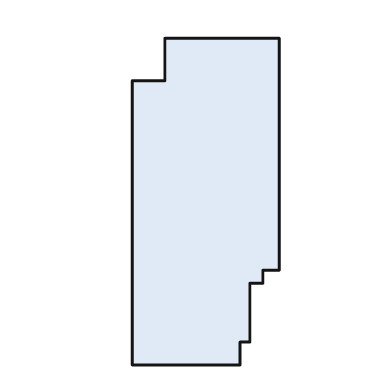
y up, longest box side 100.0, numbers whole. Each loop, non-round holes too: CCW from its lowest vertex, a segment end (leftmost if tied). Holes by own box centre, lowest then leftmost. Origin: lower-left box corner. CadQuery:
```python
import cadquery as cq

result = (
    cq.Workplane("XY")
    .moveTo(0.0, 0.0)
    .lineTo(33.0, 0.0)
    .lineTo(33.0, 7.0)
    .lineTo(36.0, 7.0)
    .lineTo(36.0, 25.0)
    .lineTo(40.0, 25.0)
    .lineTo(40.0, 29.0)
    .lineTo(45.0, 29.0)
    .lineTo(45.0, 100.0)
    .lineTo(10.0, 100.0)
    .lineTo(10.0, 87.0)
    .lineTo(0.0, 87.0)
    .close()
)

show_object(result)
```